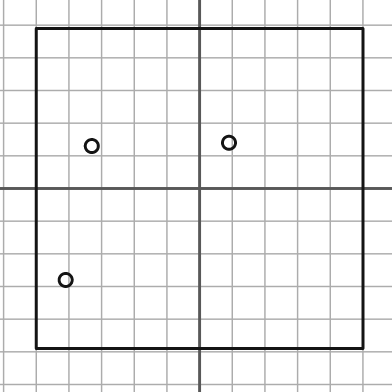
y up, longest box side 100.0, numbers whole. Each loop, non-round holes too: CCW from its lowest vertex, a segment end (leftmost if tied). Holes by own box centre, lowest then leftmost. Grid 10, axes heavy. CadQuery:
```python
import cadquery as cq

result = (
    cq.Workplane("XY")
    .moveTo(-50.0, -49.0)
    .lineTo(50.0, -49.0)
    .lineTo(50.0, 49.0)
    .lineTo(-50.0, 49.0)
    .close()
    .moveTo(-41.0, -28.0)
    .circle(2.0)
    .moveTo(-33.0, 13.0)
    .circle(2.0)
    .moveTo(9.0, 14.0)
    .circle(2.0)
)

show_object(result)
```